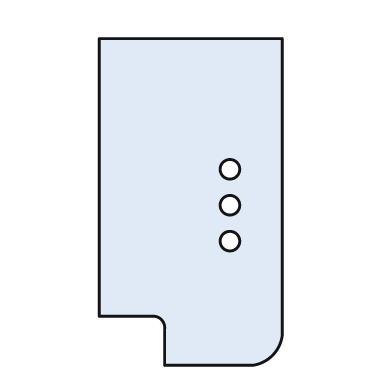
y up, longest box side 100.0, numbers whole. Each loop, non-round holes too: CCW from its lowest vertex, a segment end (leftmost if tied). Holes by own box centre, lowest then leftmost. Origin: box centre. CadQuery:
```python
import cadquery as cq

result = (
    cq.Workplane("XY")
    .moveTo(-8.0, -50.0)
    .lineTo(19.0, -50.0)
    .threePointArc((25.0, -47.0), (28.0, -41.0))
    .lineTo(28.0, 50.0)
    .lineTo(-28.0, 50.0)
    .lineTo(-28.0, -35.0)
    .lineTo(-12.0, -35.0)
    .threePointArc((-9.0, -36.0), (-8.0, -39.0))
    .close()
    .moveTo(12.0, -12.0)
    .circle(3.0)
    .moveTo(12.0, -1.0)
    .circle(3.0)
    .moveTo(12.0, 10.0)
    .circle(3.0)
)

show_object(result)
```